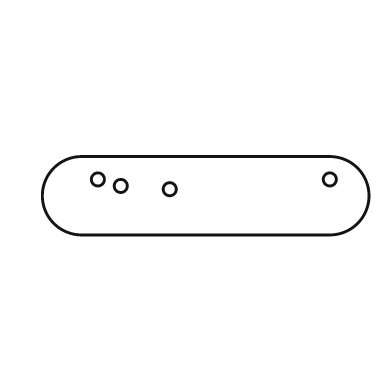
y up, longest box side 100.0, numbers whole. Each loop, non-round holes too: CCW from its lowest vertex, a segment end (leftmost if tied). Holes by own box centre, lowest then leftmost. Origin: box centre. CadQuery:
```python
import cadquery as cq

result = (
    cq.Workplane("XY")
    .moveTo(-38.0, -12.0)
    .lineTo(38.0, -12.0)
    .threePointArc((50.0, 0.0), (38.0, 12.0))
    .lineTo(-38.0, 12.0)
    .threePointArc((-50.0, 0.0), (-38.0, -12.0))
    .close()
    .moveTo(-11.0, 2.0)
    .circle(2.0)
    .moveTo(-26.0, 3.0)
    .circle(2.0)
    .moveTo(-33.0, 5.0)
    .circle(2.0)
    .moveTo(38.0, 5.0)
    .circle(2.0)
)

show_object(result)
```